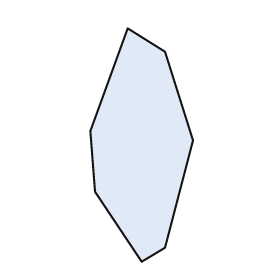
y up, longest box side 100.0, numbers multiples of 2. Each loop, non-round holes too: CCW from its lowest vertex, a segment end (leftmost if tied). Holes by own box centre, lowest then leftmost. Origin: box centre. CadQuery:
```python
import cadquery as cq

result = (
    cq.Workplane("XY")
    .moveTo(0.0, -50.0)
    .lineTo(10.0, -44.0)
    .lineTo(22.0, 2.0)
    .lineTo(10.0, 40.0)
    .lineTo(-6.0, 50.0)
    .lineTo(-22.0, 6.0)
    .lineTo(-20.0, -20.0)
    .close()
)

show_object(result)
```